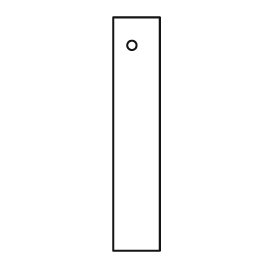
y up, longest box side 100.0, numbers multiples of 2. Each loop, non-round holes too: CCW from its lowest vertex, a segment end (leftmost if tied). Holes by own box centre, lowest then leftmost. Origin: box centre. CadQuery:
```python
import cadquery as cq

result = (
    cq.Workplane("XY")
    .moveTo(-10.0, -50.0)
    .lineTo(10.0, -50.0)
    .lineTo(10.0, 50.0)
    .lineTo(-10.0, 50.0)
    .close()
    .moveTo(-2.0, 38.0)
    .circle(2.0)
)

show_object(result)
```